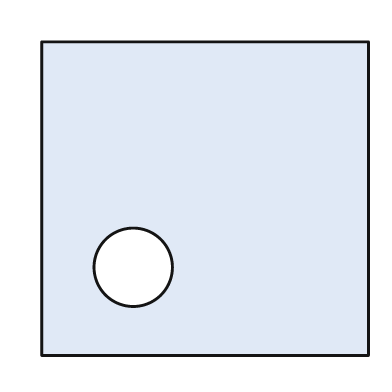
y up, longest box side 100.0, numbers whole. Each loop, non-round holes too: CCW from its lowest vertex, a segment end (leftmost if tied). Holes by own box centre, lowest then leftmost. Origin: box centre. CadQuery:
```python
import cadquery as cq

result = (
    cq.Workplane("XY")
    .moveTo(-50.0, -48.0)
    .lineTo(50.0, -48.0)
    .lineTo(50.0, 48.0)
    .lineTo(-50.0, 48.0)
    .close()
    .moveTo(-22.0, -21.0)
    .circle(12.0)
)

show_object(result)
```